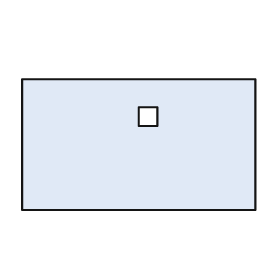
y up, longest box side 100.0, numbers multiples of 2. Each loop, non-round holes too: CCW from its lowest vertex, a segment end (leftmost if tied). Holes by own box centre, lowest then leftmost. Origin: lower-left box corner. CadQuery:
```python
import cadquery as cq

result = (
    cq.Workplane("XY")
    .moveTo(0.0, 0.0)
    .lineTo(100.0, 0.0)
    .lineTo(100.0, 56.0)
    .lineTo(0.0, 56.0)
    .close()
    .moveTo(50.0, 36.0)
    .lineTo(58.0, 36.0)
    .lineTo(58.0, 44.0)
    .lineTo(50.0, 44.0)
    .close()
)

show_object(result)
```